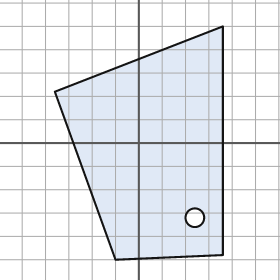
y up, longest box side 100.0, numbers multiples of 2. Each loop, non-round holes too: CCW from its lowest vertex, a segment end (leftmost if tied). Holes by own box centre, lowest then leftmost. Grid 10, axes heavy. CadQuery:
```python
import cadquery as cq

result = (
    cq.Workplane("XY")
    .moveTo(-10.0, -50.0)
    .lineTo(36.0, -48.0)
    .lineTo(36.0, 50.0)
    .lineTo(-36.0, 22.0)
    .close()
    .moveTo(24.0, -32.0)
    .circle(4.0)
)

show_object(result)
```